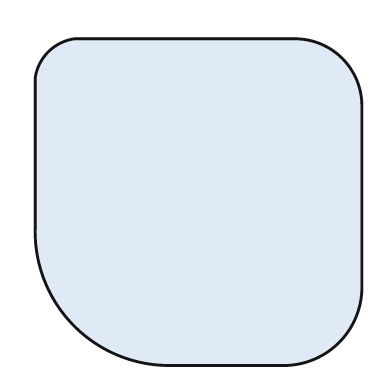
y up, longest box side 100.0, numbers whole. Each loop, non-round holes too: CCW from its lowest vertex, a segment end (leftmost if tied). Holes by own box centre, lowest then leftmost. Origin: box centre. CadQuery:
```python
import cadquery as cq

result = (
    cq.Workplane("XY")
    .moveTo(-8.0, -50.0)
    .lineTo(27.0, -50.0)
    .threePointArc((43.0, -43.0), (50.0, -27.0))
    .lineTo(50.0, 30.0)
    .threePointArc((44.0, 44.0), (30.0, 50.0))
    .lineTo(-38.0, 50.0)
    .threePointArc((-46.0, 46.0), (-50.0, 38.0))
    .lineTo(-50.0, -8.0)
    .threePointArc((-38.0, -38.0), (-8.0, -50.0))
    .close()
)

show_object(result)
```